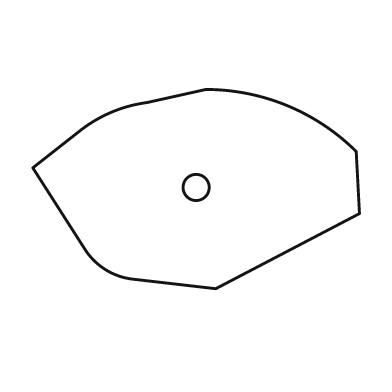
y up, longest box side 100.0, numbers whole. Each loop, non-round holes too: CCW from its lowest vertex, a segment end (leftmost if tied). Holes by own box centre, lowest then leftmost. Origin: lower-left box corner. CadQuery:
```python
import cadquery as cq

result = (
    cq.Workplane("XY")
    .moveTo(56.0, 0.0)
    .lineTo(100.0, 23.0)
    .lineTo(99.0, 42.0)
    .threePointArc((78.0, 56.0), (53.0, 61.0))
    .lineTo(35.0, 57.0)
    .threePointArc((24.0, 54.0), (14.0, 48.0))
    .lineTo(0.0, 37.0)
    .lineTo(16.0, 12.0)
    .threePointArc((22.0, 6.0), (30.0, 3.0))
    .close()
    .moveTo(50.0, 31.0)
    .circle(4.0)
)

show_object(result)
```